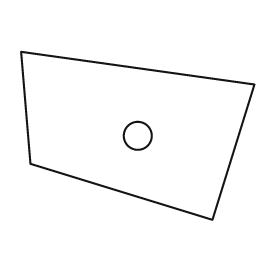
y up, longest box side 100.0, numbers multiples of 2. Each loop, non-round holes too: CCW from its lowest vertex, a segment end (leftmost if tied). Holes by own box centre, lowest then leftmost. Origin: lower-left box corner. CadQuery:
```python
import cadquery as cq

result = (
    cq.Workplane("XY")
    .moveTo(82.0, 0.0)
    .lineTo(100.0, 58.0)
    .lineTo(0.0, 72.0)
    .lineTo(4.0, 24.0)
    .close()
    .moveTo(50.0, 36.0)
    .circle(6.0)
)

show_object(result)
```